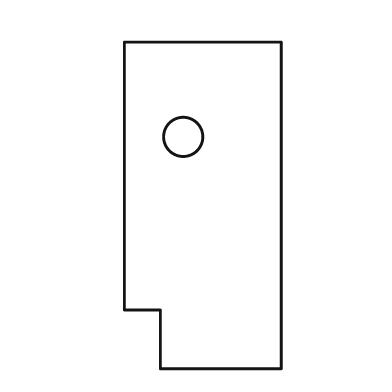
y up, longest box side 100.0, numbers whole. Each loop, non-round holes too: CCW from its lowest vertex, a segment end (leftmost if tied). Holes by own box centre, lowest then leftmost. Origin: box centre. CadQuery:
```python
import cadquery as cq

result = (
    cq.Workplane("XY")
    .moveTo(-13.0, -50.0)
    .lineTo(24.0, -50.0)
    .lineTo(24.0, 50.0)
    .lineTo(-24.0, 50.0)
    .lineTo(-24.0, -32.0)
    .lineTo(-13.0, -32.0)
    .close()
    .moveTo(-6.0, 21.0)
    .circle(6.0)
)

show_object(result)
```